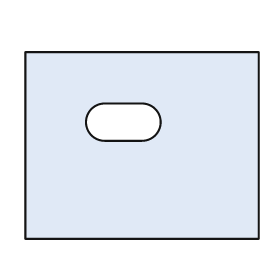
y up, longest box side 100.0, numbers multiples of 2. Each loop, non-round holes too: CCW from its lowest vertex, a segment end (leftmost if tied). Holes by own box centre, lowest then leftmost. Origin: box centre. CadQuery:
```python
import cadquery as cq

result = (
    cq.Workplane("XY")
    .moveTo(-50.0, -40.0)
    .lineTo(50.0, -40.0)
    .lineTo(50.0, 40.0)
    .lineTo(-50.0, 40.0)
    .close()
    .moveTo(-16.0, 2.0)
    .lineTo(0.0, 2.0)
    .threePointArc((8.0, 10.0), (0.0, 18.0))
    .lineTo(-16.0, 18.0)
    .threePointArc((-24.0, 10.0), (-16.0, 2.0))
    .close()
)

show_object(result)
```